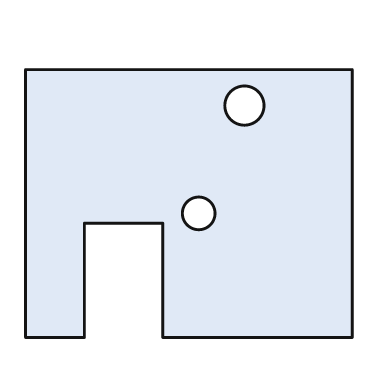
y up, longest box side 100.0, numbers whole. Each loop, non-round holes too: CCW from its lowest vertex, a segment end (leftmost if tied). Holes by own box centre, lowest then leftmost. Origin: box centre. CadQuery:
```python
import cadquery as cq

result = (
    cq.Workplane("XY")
    .moveTo(-50.0, -41.0)
    .lineTo(-32.0, -41.0)
    .lineTo(-32.0, -6.0)
    .lineTo(-8.0, -6.0)
    .lineTo(-8.0, -41.0)
    .lineTo(50.0, -41.0)
    .lineTo(50.0, 41.0)
    .lineTo(-50.0, 41.0)
    .close()
    .moveTo(3.0, -3.0)
    .circle(5.0)
    .moveTo(17.0, 30.0)
    .circle(6.0)
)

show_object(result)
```